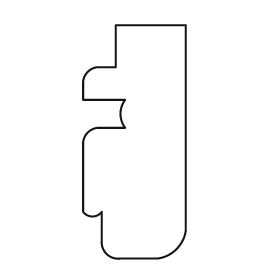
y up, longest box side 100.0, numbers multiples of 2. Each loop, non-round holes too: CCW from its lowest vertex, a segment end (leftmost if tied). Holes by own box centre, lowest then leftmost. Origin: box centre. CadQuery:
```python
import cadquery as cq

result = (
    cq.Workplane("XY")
    .moveTo(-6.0, -50.0)
    .lineTo(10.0, -50.0)
    .threePointArc((18.0, -46.0), (22.0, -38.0))
    .lineTo(22.0, 50.0)
    .lineTo(-8.0, 50.0)
    .lineTo(-8.0, 32.0)
    .lineTo(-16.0, 32.0)
    .threePointArc((-20.0, 30.0), (-22.0, 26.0))
    .lineTo(-22.0, 18.0)
    .lineTo(-4.0, 18.0)
    .threePointArc((-6.0, 12.0), (-4.0, 6.0))
    .lineTo(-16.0, 6.0)
    .threePointArc((-20.0, 4.0), (-22.0, 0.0))
    .lineTo(-22.0, -30.0)
    .threePointArc((-18.0, -32.0), (-14.0, -30.0))
    .lineTo(-14.0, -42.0)
    .threePointArc((-12.0, -48.0), (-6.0, -50.0))
    .close()
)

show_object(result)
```